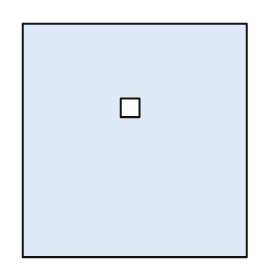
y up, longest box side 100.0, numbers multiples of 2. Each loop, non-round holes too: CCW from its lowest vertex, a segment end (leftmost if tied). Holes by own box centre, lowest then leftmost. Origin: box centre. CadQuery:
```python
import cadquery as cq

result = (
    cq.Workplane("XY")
    .moveTo(-48.0, -50.0)
    .lineTo(48.0, -50.0)
    .lineTo(48.0, 50.0)
    .lineTo(-48.0, 50.0)
    .close()
    .moveTo(-6.0, 10.0)
    .lineTo(2.0, 10.0)
    .lineTo(2.0, 18.0)
    .lineTo(-6.0, 18.0)
    .close()
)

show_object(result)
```